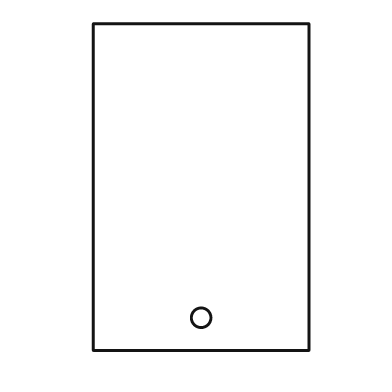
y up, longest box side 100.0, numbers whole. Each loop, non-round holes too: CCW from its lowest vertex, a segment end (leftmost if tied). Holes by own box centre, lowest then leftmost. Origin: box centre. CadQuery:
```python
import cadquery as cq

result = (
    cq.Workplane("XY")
    .moveTo(-33.0, -50.0)
    .lineTo(33.0, -50.0)
    .lineTo(33.0, 50.0)
    .lineTo(-33.0, 50.0)
    .close()
    .moveTo(0.0, -40.0)
    .circle(3.0)
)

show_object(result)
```